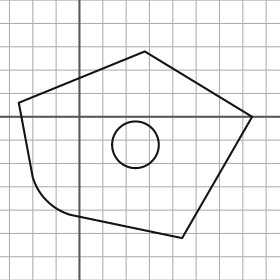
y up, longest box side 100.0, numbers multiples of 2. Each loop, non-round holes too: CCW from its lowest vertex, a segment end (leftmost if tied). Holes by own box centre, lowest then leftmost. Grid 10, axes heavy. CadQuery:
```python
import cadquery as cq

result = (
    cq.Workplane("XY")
    .moveTo(44.0, -52.0)
    .lineTo(74.0, 0.0)
    .lineTo(28.0, 28.0)
    .lineTo(-26.0, 6.0)
    .lineTo(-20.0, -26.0)
    .threePointArc((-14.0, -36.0), (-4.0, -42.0))
    .close()
    .moveTo(24.0, -12.0)
    .circle(10.0)
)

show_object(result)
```